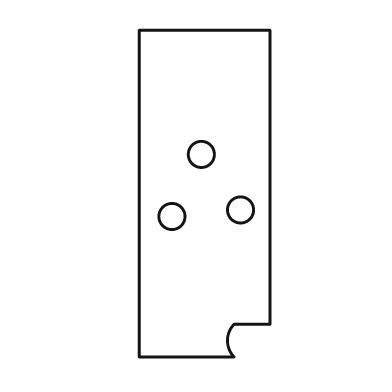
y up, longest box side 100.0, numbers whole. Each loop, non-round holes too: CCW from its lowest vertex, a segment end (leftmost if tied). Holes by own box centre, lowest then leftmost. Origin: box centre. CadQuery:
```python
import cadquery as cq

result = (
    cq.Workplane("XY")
    .moveTo(-20.0, -50.0)
    .lineTo(9.0, -50.0)
    .threePointArc((7.0, -45.0), (9.0, -40.0))
    .lineTo(20.0, -40.0)
    .lineTo(20.0, 50.0)
    .lineTo(-20.0, 50.0)
    .close()
    .moveTo(-10.0, -7.0)
    .circle(4.0)
    .moveTo(11.0, -5.0)
    .circle(4.0)
    .moveTo(-1.0, 12.0)
    .circle(4.0)
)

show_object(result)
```